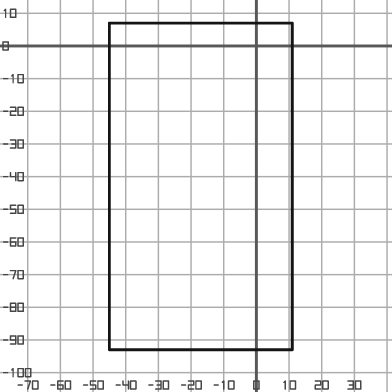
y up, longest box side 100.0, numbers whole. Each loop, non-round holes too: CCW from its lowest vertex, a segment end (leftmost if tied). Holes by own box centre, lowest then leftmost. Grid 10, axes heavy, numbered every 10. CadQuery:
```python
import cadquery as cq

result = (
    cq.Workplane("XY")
    .moveTo(-45.0, -93.0)
    .lineTo(11.0, -93.0)
    .lineTo(11.0, 7.0)
    .lineTo(-45.0, 7.0)
    .close()
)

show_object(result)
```